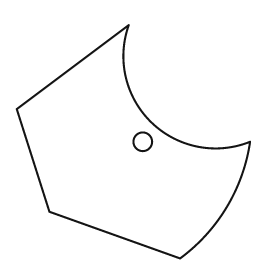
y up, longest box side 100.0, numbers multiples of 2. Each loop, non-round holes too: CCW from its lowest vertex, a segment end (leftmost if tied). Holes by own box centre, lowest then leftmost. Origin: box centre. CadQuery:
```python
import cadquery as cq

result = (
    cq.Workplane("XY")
    .moveTo(20.0, -50.0)
    .threePointArc((40.0, -28.0), (50.0, 0.0))
    .threePointArc((8.0, 8.0), (-2.0, 50.0))
    .lineTo(-50.0, 14.0)
    .lineTo(-36.0, -30.0)
    .close()
    .moveTo(4.0, 0.0)
    .circle(4.0)
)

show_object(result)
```